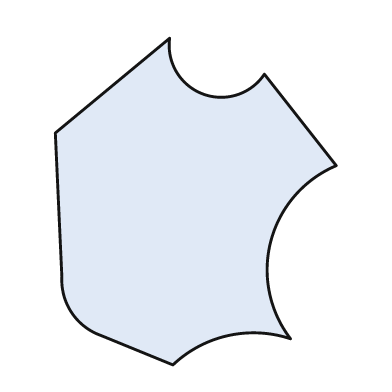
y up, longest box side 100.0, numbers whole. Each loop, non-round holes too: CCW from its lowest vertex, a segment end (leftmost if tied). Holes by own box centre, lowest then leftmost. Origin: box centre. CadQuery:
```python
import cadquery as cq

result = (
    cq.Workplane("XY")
    .moveTo(-7.0, -50.0)
    .threePointArc((10.0, -41.0), (29.0, -42.0))
    .threePointArc((23.0, -12.0), (43.0, 11.0))
    .lineTo(21.0, 39.0)
    .threePointArc((2.0, 33.0), (-8.0, 50.0))
    .lineTo(-43.0, 21.0)
    .lineTo(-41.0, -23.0)
    .threePointArc((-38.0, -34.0), (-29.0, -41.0))
    .close()
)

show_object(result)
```